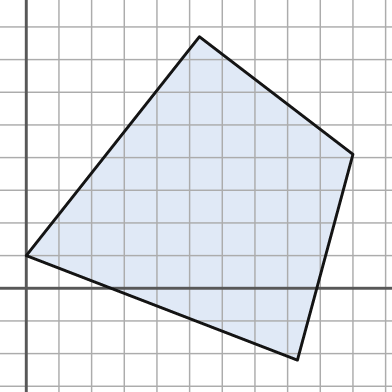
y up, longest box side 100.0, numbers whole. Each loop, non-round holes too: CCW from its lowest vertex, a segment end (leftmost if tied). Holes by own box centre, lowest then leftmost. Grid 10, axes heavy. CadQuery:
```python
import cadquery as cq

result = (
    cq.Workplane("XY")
    .moveTo(83.0, -22.0)
    .lineTo(100.0, 41.0)
    .lineTo(53.0, 77.0)
    .lineTo(0.0, 10.0)
    .close()
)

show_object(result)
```